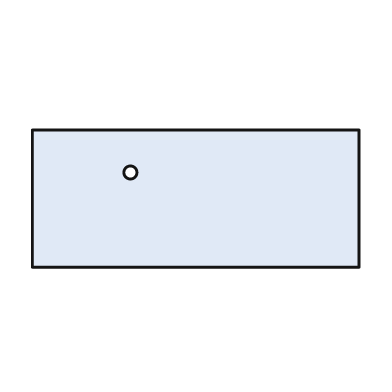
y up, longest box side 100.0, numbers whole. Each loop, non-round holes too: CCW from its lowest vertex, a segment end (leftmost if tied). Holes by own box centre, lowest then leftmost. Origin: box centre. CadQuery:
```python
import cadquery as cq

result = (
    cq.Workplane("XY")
    .moveTo(-50.0, -21.0)
    .lineTo(50.0, -21.0)
    .lineTo(50.0, 21.0)
    .lineTo(-50.0, 21.0)
    .close()
    .moveTo(-20.0, 8.0)
    .circle(2.0)
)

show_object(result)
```